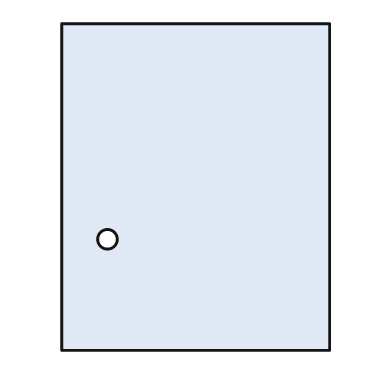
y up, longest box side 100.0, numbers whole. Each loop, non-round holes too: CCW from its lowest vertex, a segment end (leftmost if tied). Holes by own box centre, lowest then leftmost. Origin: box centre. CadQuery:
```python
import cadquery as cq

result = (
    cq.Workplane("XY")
    .moveTo(-41.0, -50.0)
    .lineTo(41.0, -50.0)
    .lineTo(41.0, 50.0)
    .lineTo(-41.0, 50.0)
    .close()
    .moveTo(-27.0, -16.0)
    .circle(3.0)
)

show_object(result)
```